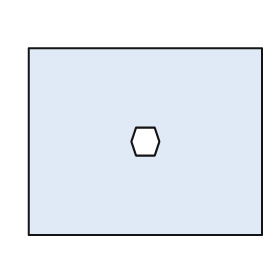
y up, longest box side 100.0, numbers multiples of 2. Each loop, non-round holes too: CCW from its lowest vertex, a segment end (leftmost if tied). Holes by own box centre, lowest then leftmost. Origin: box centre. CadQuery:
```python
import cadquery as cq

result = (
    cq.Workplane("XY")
    .moveTo(-50.0, -40.0)
    .lineTo(50.0, -40.0)
    .lineTo(50.0, 40.0)
    .lineTo(-50.0, 40.0)
    .close()
    .moveTo(-4.0, -6.0)
    .lineTo(4.0, -6.0)
    .lineTo(6.0, 0.0)
    .lineTo(4.0, 6.0)
    .lineTo(-4.0, 6.0)
    .lineTo(-6.0, 0.0)
    .close()
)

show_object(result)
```